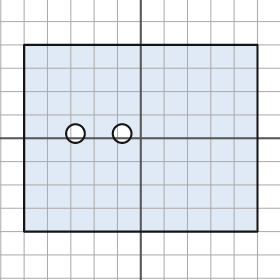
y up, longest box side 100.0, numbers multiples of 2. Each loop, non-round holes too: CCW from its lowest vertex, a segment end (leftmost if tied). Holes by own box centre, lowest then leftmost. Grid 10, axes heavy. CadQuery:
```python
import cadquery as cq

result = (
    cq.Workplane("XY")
    .moveTo(-50.0, -40.0)
    .lineTo(50.0, -40.0)
    .lineTo(50.0, 40.0)
    .lineTo(-50.0, 40.0)
    .close()
    .moveTo(-28.0, 2.0)
    .circle(4.0)
    .moveTo(-8.0, 2.0)
    .circle(4.0)
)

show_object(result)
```